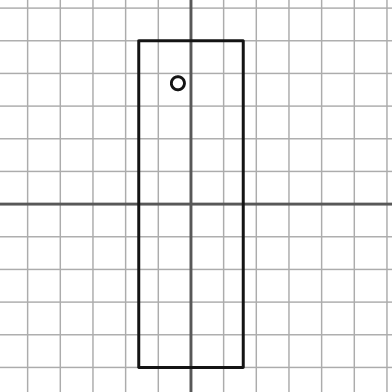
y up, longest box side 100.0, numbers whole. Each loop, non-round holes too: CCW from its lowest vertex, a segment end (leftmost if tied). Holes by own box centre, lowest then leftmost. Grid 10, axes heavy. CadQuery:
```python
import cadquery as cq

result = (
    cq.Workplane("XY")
    .moveTo(-16.0, -50.0)
    .lineTo(16.0, -50.0)
    .lineTo(16.0, 50.0)
    .lineTo(-16.0, 50.0)
    .close()
    .moveTo(-4.0, 37.0)
    .circle(2.0)
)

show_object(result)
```